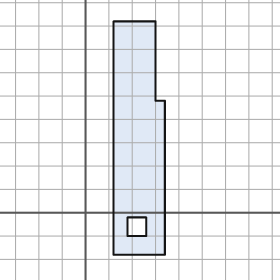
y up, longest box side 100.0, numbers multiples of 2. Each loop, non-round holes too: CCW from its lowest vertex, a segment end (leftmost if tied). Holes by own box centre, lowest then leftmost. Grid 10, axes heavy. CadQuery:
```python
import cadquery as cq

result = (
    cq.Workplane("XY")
    .moveTo(12.0, -18.0)
    .lineTo(34.0, -18.0)
    .lineTo(34.0, 48.0)
    .lineTo(30.0, 48.0)
    .lineTo(30.0, 82.0)
    .lineTo(12.0, 82.0)
    .close()
    .moveTo(18.0, -10.0)
    .lineTo(26.0, -10.0)
    .lineTo(26.0, -2.0)
    .lineTo(18.0, -2.0)
    .close()
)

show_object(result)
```